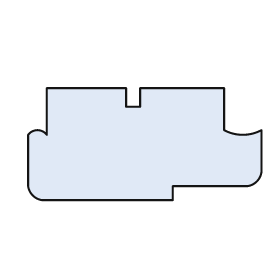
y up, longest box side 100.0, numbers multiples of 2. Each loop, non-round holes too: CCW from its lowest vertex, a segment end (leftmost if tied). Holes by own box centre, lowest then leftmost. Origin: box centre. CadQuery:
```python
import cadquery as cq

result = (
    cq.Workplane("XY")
    .moveTo(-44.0, -24.0)
    .lineTo(12.0, -24.0)
    .lineTo(12.0, -18.0)
    .lineTo(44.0, -18.0)
    .threePointArc((48.0, -16.0), (50.0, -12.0))
    .lineTo(50.0, 6.0)
    .threePointArc((42.0, 4.0), (34.0, 6.0))
    .lineTo(34.0, 24.0)
    .lineTo(-2.0, 24.0)
    .lineTo(-2.0, 16.0)
    .lineTo(-8.0, 16.0)
    .lineTo(-8.0, 24.0)
    .lineTo(-42.0, 24.0)
    .lineTo(-42.0, 4.0)
    .threePointArc((-46.0, 6.0), (-50.0, 4.0))
    .lineTo(-50.0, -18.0)
    .threePointArc((-48.0, -22.0), (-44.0, -24.0))
    .close()
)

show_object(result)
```